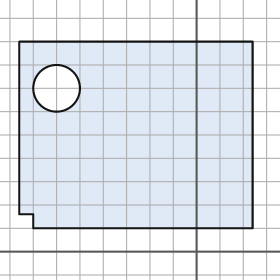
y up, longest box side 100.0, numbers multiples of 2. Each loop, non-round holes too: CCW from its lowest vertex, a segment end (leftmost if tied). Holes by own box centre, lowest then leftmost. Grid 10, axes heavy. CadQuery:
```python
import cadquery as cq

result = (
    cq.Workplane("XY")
    .moveTo(-70.0, 10.0)
    .lineTo(24.0, 10.0)
    .lineTo(24.0, 90.0)
    .lineTo(-76.0, 90.0)
    .lineTo(-76.0, 16.0)
    .lineTo(-70.0, 16.0)
    .close()
    .moveTo(-60.0, 70.0)
    .circle(10.0)
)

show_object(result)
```